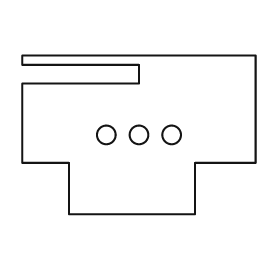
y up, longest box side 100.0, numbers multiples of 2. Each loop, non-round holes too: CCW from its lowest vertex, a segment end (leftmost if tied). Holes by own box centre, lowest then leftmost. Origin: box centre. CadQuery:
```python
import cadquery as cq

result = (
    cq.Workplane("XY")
    .moveTo(-30.0, -34.0)
    .lineTo(24.0, -34.0)
    .lineTo(24.0, -12.0)
    .lineTo(50.0, -12.0)
    .lineTo(50.0, 34.0)
    .lineTo(-50.0, 34.0)
    .lineTo(-50.0, 30.0)
    .lineTo(0.0, 30.0)
    .lineTo(0.0, 22.0)
    .lineTo(-50.0, 22.0)
    .lineTo(-50.0, -12.0)
    .lineTo(-30.0, -12.0)
    .close()
    .moveTo(-14.0, 0.0)
    .circle(4.0)
    .moveTo(0.0, 0.0)
    .circle(4.0)
    .moveTo(14.0, 0.0)
    .circle(4.0)
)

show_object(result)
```